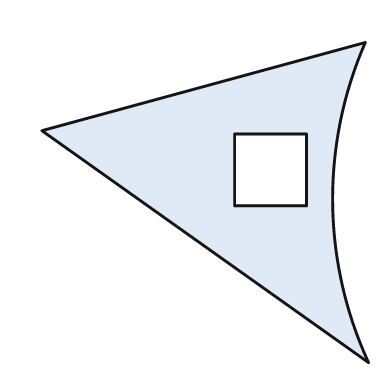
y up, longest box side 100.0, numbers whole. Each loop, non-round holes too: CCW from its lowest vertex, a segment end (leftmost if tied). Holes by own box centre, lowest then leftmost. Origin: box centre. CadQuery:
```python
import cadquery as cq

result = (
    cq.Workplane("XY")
    .moveTo(50.0, -49.0)
    .threePointArc((39.0, 0.0), (49.0, 49.0))
    .lineTo(-50.0, 22.0)
    .close()
    .moveTo(9.0, -1.0)
    .lineTo(31.0, -1.0)
    .lineTo(31.0, 21.0)
    .lineTo(9.0, 21.0)
    .close()
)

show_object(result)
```